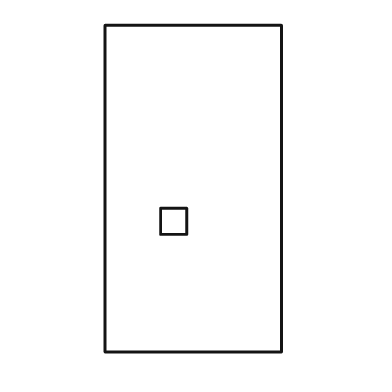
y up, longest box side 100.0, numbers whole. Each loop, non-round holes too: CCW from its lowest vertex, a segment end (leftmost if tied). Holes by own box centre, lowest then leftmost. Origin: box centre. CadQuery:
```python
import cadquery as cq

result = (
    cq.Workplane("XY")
    .moveTo(-27.0, -50.0)
    .lineTo(27.0, -50.0)
    .lineTo(27.0, 50.0)
    .lineTo(-27.0, 50.0)
    .close()
    .moveTo(-10.0, -14.0)
    .lineTo(-2.0, -14.0)
    .lineTo(-2.0, -6.0)
    .lineTo(-10.0, -6.0)
    .close()
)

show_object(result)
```